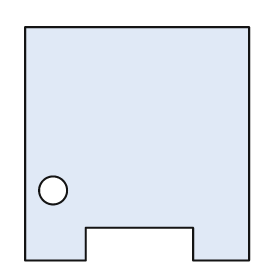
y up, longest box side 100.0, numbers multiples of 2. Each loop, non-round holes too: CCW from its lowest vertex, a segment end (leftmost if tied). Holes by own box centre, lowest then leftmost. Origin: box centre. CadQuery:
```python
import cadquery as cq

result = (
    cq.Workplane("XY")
    .moveTo(-48.0, -50.0)
    .lineTo(-22.0, -50.0)
    .lineTo(-22.0, -36.0)
    .lineTo(24.0, -36.0)
    .lineTo(24.0, -50.0)
    .lineTo(48.0, -50.0)
    .lineTo(48.0, 50.0)
    .lineTo(-48.0, 50.0)
    .close()
    .moveTo(-36.0, -20.0)
    .circle(6.0)
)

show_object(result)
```